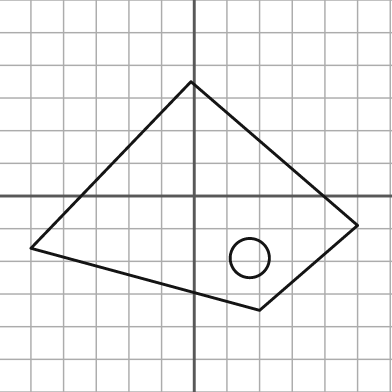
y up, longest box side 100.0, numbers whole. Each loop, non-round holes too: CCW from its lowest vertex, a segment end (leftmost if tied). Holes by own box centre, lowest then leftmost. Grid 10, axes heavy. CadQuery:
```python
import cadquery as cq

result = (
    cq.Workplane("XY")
    .moveTo(20.0, -35.0)
    .lineTo(50.0, -9.0)
    .lineTo(-1.0, 35.0)
    .lineTo(-50.0, -16.0)
    .close()
    .moveTo(17.0, -19.0)
    .circle(6.0)
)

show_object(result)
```